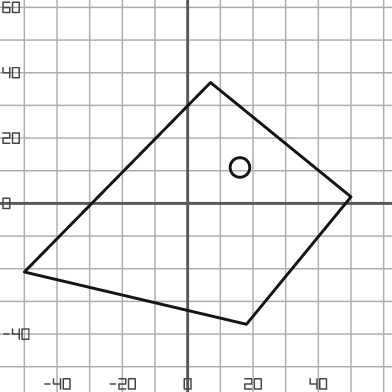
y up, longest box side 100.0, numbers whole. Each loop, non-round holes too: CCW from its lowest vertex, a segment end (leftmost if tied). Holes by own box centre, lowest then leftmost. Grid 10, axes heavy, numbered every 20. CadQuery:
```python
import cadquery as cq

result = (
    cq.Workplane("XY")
    .moveTo(18.0, -37.0)
    .lineTo(50.0, 2.0)
    .lineTo(7.0, 37.0)
    .lineTo(-50.0, -21.0)
    .close()
    .moveTo(16.0, 11.0)
    .circle(3.0)
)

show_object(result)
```